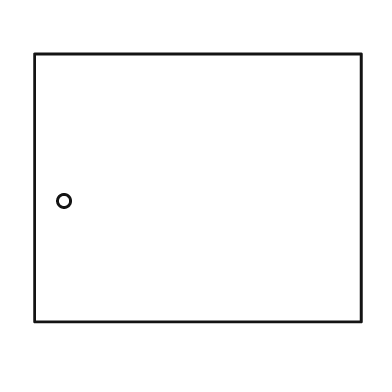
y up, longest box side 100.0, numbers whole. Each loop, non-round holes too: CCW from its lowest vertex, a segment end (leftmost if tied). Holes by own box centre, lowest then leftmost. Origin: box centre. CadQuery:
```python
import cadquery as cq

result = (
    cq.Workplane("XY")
    .moveTo(-50.0, -41.0)
    .lineTo(50.0, -41.0)
    .lineTo(50.0, 41.0)
    .lineTo(-50.0, 41.0)
    .close()
    .moveTo(-41.0, -4.0)
    .circle(2.0)
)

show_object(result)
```